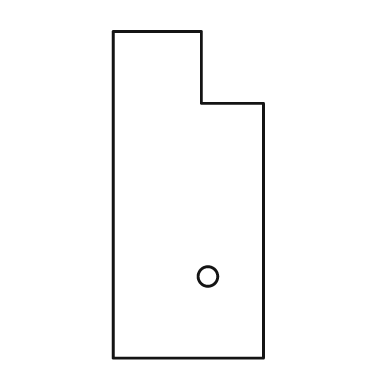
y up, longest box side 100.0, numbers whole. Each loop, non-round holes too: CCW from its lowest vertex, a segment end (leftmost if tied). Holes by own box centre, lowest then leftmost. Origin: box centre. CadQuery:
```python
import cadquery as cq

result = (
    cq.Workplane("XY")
    .moveTo(-23.0, -50.0)
    .lineTo(23.0, -50.0)
    .lineTo(23.0, 28.0)
    .lineTo(4.0, 28.0)
    .lineTo(4.0, 50.0)
    .lineTo(-23.0, 50.0)
    .close()
    .moveTo(6.0, -25.0)
    .circle(3.0)
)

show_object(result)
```